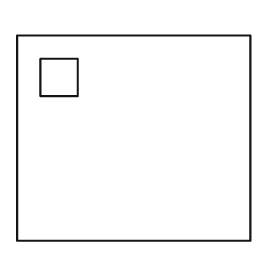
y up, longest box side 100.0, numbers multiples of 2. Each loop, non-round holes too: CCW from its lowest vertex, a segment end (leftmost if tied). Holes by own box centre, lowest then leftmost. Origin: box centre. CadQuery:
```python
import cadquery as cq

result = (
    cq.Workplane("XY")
    .moveTo(-50.0, -44.0)
    .lineTo(50.0, -44.0)
    .lineTo(50.0, 44.0)
    .lineTo(-50.0, 44.0)
    .close()
    .moveTo(-40.0, 18.0)
    .lineTo(-24.0, 18.0)
    .lineTo(-24.0, 34.0)
    .lineTo(-40.0, 34.0)
    .close()
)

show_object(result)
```